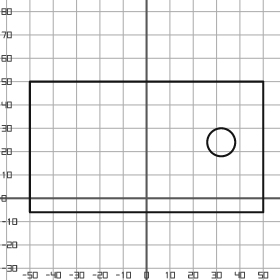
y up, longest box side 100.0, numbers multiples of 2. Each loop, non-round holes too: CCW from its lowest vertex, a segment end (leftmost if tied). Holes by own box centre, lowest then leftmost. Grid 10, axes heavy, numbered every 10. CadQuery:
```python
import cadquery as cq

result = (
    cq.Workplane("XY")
    .moveTo(-50.0, -6.0)
    .lineTo(50.0, -6.0)
    .lineTo(50.0, 50.0)
    .lineTo(-50.0, 50.0)
    .close()
    .moveTo(32.0, 24.0)
    .circle(6.0)
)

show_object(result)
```